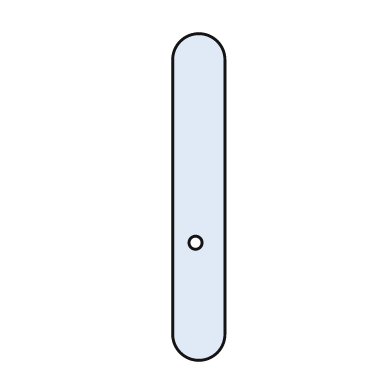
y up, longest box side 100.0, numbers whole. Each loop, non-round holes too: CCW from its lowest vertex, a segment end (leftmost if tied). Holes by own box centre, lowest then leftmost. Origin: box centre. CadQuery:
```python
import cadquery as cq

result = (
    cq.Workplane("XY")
    .moveTo(-8.0, -42.0)
    .threePointArc((0.0, -50.0), (8.0, -42.0))
    .lineTo(8.0, 42.0)
    .threePointArc((0.0, 50.0), (-8.0, 42.0))
    .close()
    .moveTo(-1.0, -14.0)
    .circle(2.0)
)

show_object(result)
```